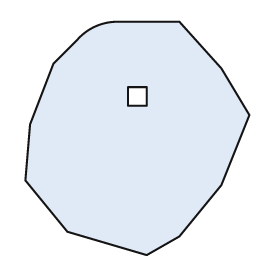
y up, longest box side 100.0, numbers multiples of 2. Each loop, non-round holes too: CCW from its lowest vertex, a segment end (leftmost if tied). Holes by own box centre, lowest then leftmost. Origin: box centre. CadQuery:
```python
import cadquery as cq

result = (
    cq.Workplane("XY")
    .moveTo(4.0, -50.0)
    .lineTo(18.0, -42.0)
    .lineTo(36.0, -20.0)
    .lineTo(48.0, 10.0)
    .lineTo(36.0, 30.0)
    .lineTo(18.0, 50.0)
    .lineTo(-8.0, 50.0)
    .threePointArc((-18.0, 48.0), (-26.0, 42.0))
    .lineTo(-36.0, 32.0)
    .lineTo(-46.0, 6.0)
    .lineTo(-48.0, -18.0)
    .lineTo(-30.0, -40.0)
    .close()
    .moveTo(-4.0, 14.0)
    .lineTo(4.0, 14.0)
    .lineTo(4.0, 22.0)
    .lineTo(-4.0, 22.0)
    .close()
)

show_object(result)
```